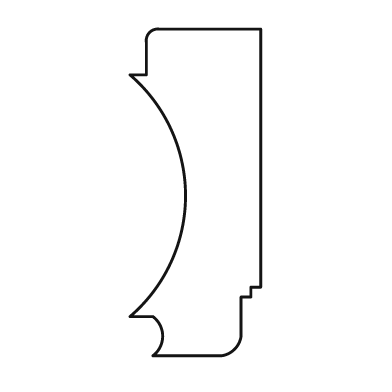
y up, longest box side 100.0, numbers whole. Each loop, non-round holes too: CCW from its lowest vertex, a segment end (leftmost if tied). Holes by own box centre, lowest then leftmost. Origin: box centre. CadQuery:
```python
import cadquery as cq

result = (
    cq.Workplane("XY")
    .moveTo(-13.0, -50.0)
    .lineTo(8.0, -50.0)
    .threePointArc((12.0, -48.0), (14.0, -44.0))
    .lineTo(14.0, -32.0)
    .lineTo(17.0, -32.0)
    .lineTo(17.0, -29.0)
    .lineTo(20.0, -29.0)
    .lineTo(20.0, 50.0)
    .lineTo(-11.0, 50.0)
    .threePointArc((-14.0, 49.0), (-15.0, 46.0))
    .lineTo(-15.0, 36.0)
    .lineTo(-20.0, 36.0)
    .threePointArc((-3.0, -1.0), (-20.0, -38.0))
    .lineTo(-13.0, -38.0)
    .threePointArc((-10.0, -44.0), (-13.0, -50.0))
    .close()
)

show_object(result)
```